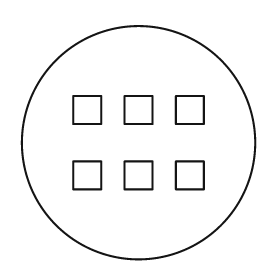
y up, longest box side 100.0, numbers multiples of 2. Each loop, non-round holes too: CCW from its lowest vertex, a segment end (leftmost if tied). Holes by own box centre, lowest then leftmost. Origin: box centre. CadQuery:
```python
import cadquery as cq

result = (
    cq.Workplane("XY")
    .moveTo(0.0, 0.0)
    .circle(50.0)
    .moveTo(-28.0, -20.0)
    .lineTo(-16.0, -20.0)
    .lineTo(-16.0, -8.0)
    .lineTo(-28.0, -8.0)
    .close()
    .moveTo(-6.0, -20.0)
    .lineTo(6.0, -20.0)
    .lineTo(6.0, -8.0)
    .lineTo(-6.0, -8.0)
    .close()
    .moveTo(16.0, -20.0)
    .lineTo(28.0, -20.0)
    .lineTo(28.0, -8.0)
    .lineTo(16.0, -8.0)
    .close()
    .moveTo(-28.0, 8.0)
    .lineTo(-16.0, 8.0)
    .lineTo(-16.0, 20.0)
    .lineTo(-28.0, 20.0)
    .close()
    .moveTo(-6.0, 8.0)
    .lineTo(6.0, 8.0)
    .lineTo(6.0, 20.0)
    .lineTo(-6.0, 20.0)
    .close()
    .moveTo(16.0, 8.0)
    .lineTo(28.0, 8.0)
    .lineTo(28.0, 20.0)
    .lineTo(16.0, 20.0)
    .close()
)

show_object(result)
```